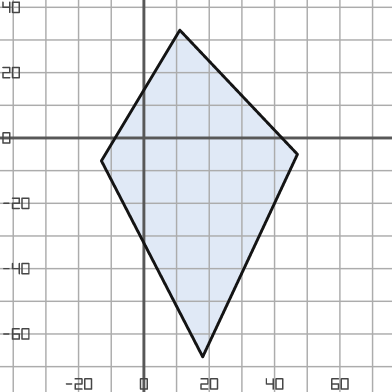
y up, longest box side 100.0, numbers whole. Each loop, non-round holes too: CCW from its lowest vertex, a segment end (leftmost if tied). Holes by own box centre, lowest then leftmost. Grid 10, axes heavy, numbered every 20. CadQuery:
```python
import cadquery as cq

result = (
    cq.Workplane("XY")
    .moveTo(18.0, -67.0)
    .lineTo(47.0, -5.0)
    .lineTo(11.0, 33.0)
    .lineTo(-13.0, -7.0)
    .close()
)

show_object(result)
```